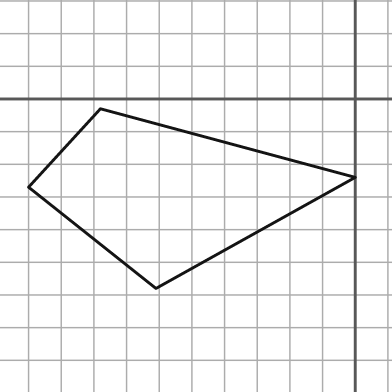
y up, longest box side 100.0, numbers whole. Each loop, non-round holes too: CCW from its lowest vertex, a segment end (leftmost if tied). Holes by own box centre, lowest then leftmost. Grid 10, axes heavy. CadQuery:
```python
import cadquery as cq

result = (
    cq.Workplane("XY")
    .moveTo(-61.0, -58.0)
    .lineTo(0.0, -24.0)
    .lineTo(-78.0, -3.0)
    .lineTo(-100.0, -27.0)
    .close()
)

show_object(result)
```